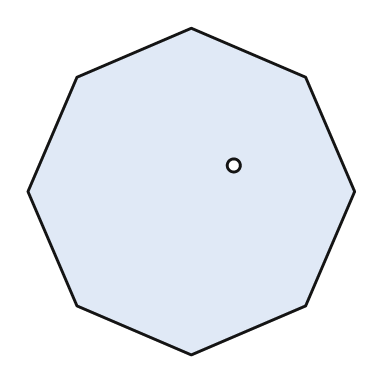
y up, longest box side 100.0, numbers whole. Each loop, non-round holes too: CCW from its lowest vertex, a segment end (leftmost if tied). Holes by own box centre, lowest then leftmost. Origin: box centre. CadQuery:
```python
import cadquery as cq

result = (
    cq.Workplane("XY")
    .moveTo(0.0, -50.0)
    .lineTo(35.0, -35.0)
    .lineTo(50.0, 0.0)
    .lineTo(35.0, 35.0)
    .lineTo(0.0, 50.0)
    .lineTo(-35.0, 35.0)
    .lineTo(-50.0, 0.0)
    .lineTo(-35.0, -35.0)
    .close()
    .moveTo(13.0, 8.0)
    .circle(2.0)
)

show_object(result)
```